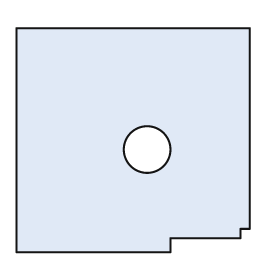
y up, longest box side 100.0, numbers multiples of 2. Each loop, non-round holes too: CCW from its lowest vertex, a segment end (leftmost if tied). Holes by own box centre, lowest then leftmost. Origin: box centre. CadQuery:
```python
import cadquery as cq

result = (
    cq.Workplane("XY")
    .moveTo(-50.0, -48.0)
    .lineTo(16.0, -48.0)
    .lineTo(16.0, -42.0)
    .lineTo(46.0, -42.0)
    .lineTo(46.0, -38.0)
    .lineTo(50.0, -38.0)
    .lineTo(50.0, 48.0)
    .lineTo(-50.0, 48.0)
    .close()
    .moveTo(6.0, -4.0)
    .circle(10.0)
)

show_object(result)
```